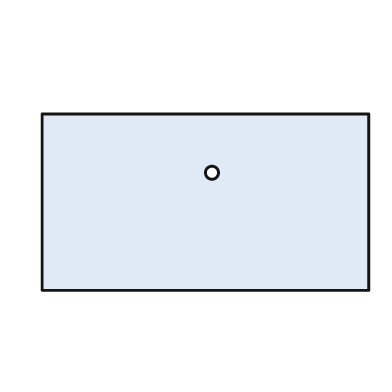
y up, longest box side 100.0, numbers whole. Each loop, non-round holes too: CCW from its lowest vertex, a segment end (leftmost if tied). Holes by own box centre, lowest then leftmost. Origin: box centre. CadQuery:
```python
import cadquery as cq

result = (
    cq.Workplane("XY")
    .moveTo(-50.0, -27.0)
    .lineTo(50.0, -27.0)
    .lineTo(50.0, 27.0)
    .lineTo(-50.0, 27.0)
    .close()
    .moveTo(2.0, 9.0)
    .circle(2.0)
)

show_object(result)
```